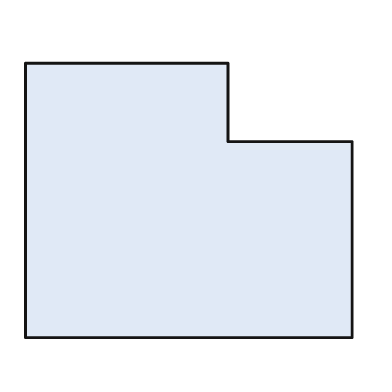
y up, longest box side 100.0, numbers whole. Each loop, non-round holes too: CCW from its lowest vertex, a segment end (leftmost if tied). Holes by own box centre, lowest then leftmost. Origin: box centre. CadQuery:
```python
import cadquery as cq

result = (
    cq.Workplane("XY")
    .moveTo(-50.0, -42.0)
    .lineTo(50.0, -42.0)
    .lineTo(50.0, 18.0)
    .lineTo(12.0, 18.0)
    .lineTo(12.0, 42.0)
    .lineTo(-50.0, 42.0)
    .close()
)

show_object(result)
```